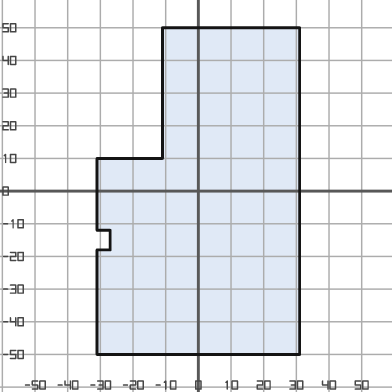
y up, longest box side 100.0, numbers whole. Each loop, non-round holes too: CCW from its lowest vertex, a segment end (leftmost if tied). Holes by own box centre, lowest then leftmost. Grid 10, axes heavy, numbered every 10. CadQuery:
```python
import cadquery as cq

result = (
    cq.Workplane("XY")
    .moveTo(-31.0, -50.0)
    .lineTo(31.0, -50.0)
    .lineTo(31.0, 50.0)
    .lineTo(-11.0, 50.0)
    .lineTo(-11.0, 10.0)
    .lineTo(-31.0, 10.0)
    .lineTo(-31.0, -12.0)
    .lineTo(-27.0, -12.0)
    .lineTo(-27.0, -18.0)
    .lineTo(-31.0, -18.0)
    .close()
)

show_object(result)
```